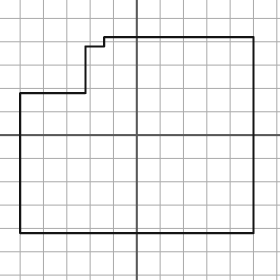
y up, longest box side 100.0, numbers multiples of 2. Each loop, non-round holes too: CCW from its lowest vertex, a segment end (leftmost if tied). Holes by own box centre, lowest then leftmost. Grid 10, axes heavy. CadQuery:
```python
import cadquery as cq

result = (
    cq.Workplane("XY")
    .moveTo(-50.0, -42.0)
    .lineTo(50.0, -42.0)
    .lineTo(50.0, 42.0)
    .lineTo(-14.0, 42.0)
    .lineTo(-14.0, 38.0)
    .lineTo(-22.0, 38.0)
    .lineTo(-22.0, 18.0)
    .lineTo(-50.0, 18.0)
    .close()
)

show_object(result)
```